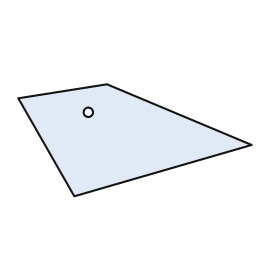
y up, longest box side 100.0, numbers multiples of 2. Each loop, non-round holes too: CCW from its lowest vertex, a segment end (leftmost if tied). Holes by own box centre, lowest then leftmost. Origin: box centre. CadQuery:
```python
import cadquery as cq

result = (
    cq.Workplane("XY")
    .moveTo(-26.0, -24.0)
    .lineTo(50.0, -2.0)
    .lineTo(-12.0, 24.0)
    .lineTo(-50.0, 18.0)
    .close()
    .moveTo(-20.0, 12.0)
    .circle(2.0)
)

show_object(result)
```